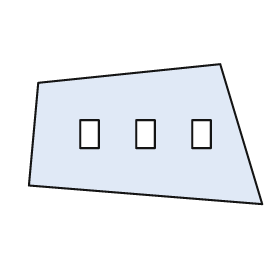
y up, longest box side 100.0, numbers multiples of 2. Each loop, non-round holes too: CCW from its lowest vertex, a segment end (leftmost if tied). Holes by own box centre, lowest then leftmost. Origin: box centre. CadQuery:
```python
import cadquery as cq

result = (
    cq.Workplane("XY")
    .moveTo(50.0, -30.0)
    .lineTo(32.0, 30.0)
    .lineTo(-46.0, 22.0)
    .lineTo(-50.0, -22.0)
    .close()
    .moveTo(-28.0, -6.0)
    .lineTo(-20.0, -6.0)
    .lineTo(-20.0, 6.0)
    .lineTo(-28.0, 6.0)
    .close()
    .moveTo(-4.0, -6.0)
    .lineTo(4.0, -6.0)
    .lineTo(4.0, 6.0)
    .lineTo(-4.0, 6.0)
    .close()
    .moveTo(20.0, -6.0)
    .lineTo(28.0, -6.0)
    .lineTo(28.0, 6.0)
    .lineTo(20.0, 6.0)
    .close()
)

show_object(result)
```